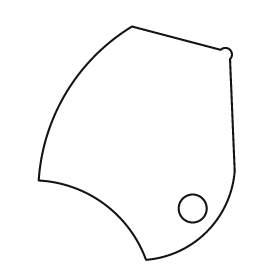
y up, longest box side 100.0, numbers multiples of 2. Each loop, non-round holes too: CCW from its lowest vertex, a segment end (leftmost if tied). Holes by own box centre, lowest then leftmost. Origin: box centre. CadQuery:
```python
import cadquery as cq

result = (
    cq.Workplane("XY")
    .moveTo(4.0, -50.0)
    .threePointArc((30.0, -38.0), (42.0, -12.0))
    .lineTo(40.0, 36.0)
    .threePointArc((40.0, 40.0), (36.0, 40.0))
    .lineTo(-2.0, 50.0)
    .threePointArc((-30.0, 22.0), (-42.0, -16.0))
    .threePointArc((-14.0, -26.0), (4.0, -50.0))
    .close()
    .moveTo(24.0, -28.0)
    .circle(6.0)
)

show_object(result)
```